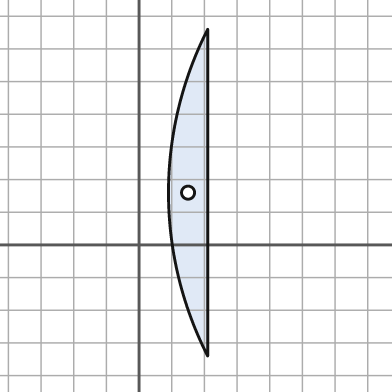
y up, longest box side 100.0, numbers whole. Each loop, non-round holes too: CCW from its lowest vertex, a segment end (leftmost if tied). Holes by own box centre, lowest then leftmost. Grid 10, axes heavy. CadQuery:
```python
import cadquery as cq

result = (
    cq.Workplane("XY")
    .moveTo(21.0, -34.0)
    .lineTo(21.0, 66.0)
    .threePointArc((9.0, 16.0), (21.0, -34.0))
    .close()
    .moveTo(15.0, 16.0)
    .circle(2.0)
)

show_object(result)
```